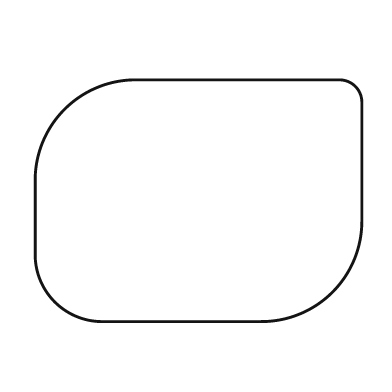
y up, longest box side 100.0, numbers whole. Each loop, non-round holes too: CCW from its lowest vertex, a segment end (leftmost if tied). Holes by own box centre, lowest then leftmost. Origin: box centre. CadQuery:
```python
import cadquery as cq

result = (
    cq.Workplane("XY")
    .moveTo(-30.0, -37.0)
    .lineTo(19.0, -37.0)
    .threePointArc((41.0, -28.0), (50.0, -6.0))
    .lineTo(50.0, 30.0)
    .threePointArc((48.0, 35.0), (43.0, 37.0))
    .lineTo(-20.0, 37.0)
    .threePointArc((-41.0, 28.0), (-50.0, 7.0))
    .lineTo(-50.0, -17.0)
    .threePointArc((-44.0, -31.0), (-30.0, -37.0))
    .close()
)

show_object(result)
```